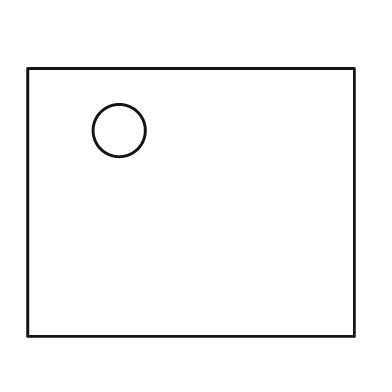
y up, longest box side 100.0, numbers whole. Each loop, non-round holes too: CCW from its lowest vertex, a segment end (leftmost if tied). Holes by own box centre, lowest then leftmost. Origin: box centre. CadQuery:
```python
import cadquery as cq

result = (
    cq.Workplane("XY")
    .moveTo(-50.0, -41.0)
    .lineTo(50.0, -41.0)
    .lineTo(50.0, 41.0)
    .lineTo(-50.0, 41.0)
    .close()
    .moveTo(-22.0, 22.0)
    .circle(8.0)
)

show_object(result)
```